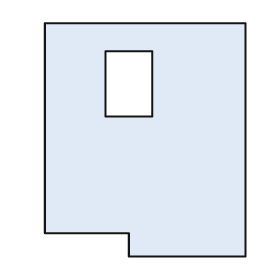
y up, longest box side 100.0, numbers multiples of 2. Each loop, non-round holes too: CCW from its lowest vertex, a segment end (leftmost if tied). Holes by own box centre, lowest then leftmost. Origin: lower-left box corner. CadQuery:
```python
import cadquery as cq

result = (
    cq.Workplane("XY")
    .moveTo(36.0, 0.0)
    .lineTo(86.0, 0.0)
    .lineTo(86.0, 100.0)
    .lineTo(0.0, 100.0)
    .lineTo(0.0, 10.0)
    .lineTo(36.0, 10.0)
    .close()
    .moveTo(26.0, 60.0)
    .lineTo(46.0, 60.0)
    .lineTo(46.0, 88.0)
    .lineTo(26.0, 88.0)
    .close()
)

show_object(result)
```